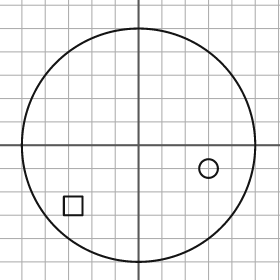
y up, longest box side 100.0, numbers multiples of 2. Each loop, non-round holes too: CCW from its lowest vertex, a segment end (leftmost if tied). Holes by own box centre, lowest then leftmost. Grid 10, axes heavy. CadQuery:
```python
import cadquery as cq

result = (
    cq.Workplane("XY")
    .moveTo(0.0, 0.0)
    .circle(50.0)
    .moveTo(-32.0, -30.0)
    .lineTo(-24.0, -30.0)
    .lineTo(-24.0, -22.0)
    .lineTo(-32.0, -22.0)
    .close()
    .moveTo(30.0, -10.0)
    .circle(4.0)
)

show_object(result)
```